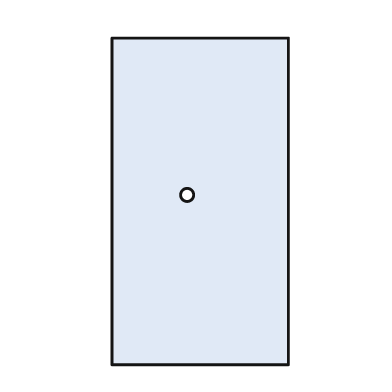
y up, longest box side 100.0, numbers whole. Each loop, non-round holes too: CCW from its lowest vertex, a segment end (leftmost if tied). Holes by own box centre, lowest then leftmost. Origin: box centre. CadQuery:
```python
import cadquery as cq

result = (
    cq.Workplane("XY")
    .moveTo(-27.0, -50.0)
    .lineTo(27.0, -50.0)
    .lineTo(27.0, 50.0)
    .lineTo(-27.0, 50.0)
    .close()
    .moveTo(-4.0, 2.0)
    .circle(2.0)
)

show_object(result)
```